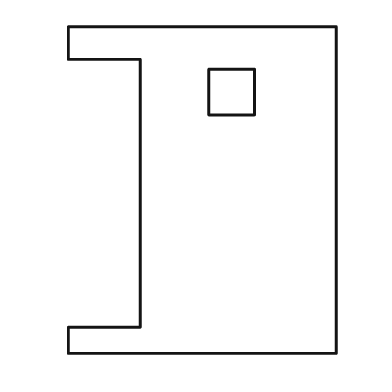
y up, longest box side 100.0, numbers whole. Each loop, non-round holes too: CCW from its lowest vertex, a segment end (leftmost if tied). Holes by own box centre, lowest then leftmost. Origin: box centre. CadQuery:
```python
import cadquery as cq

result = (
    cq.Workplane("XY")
    .moveTo(-41.0, -50.0)
    .lineTo(41.0, -50.0)
    .lineTo(41.0, 50.0)
    .lineTo(-41.0, 50.0)
    .lineTo(-41.0, 40.0)
    .lineTo(-19.0, 40.0)
    .lineTo(-19.0, -42.0)
    .lineTo(-41.0, -42.0)
    .close()
    .moveTo(2.0, 23.0)
    .lineTo(16.0, 23.0)
    .lineTo(16.0, 37.0)
    .lineTo(2.0, 37.0)
    .close()
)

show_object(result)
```